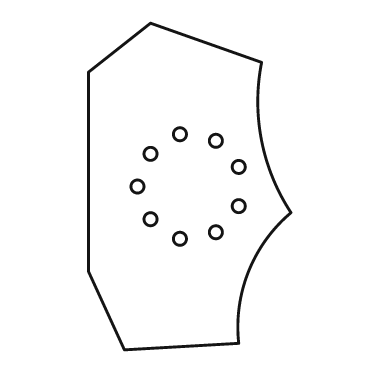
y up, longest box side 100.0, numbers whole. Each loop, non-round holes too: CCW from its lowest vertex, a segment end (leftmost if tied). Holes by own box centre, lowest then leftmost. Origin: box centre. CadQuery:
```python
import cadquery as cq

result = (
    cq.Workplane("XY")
    .moveTo(-20.0, -50.0)
    .lineTo(15.0, -48.0)
    .threePointArc((18.0, -26.0), (31.0, -8.0))
    .threePointArc((22.0, 14.0), (22.0, 38.0))
    .lineTo(-12.0, 50.0)
    .lineTo(-31.0, 35.0)
    .lineTo(-31.0, -26.0)
    .close()
    .moveTo(-3.0, -16.0)
    .circle(2.0)
    .moveTo(8.0, -14.0)
    .circle(2.0)
    .moveTo(-12.0, -10.0)
    .circle(2.0)
    .moveTo(15.0, -6.0)
    .circle(2.0)
    .moveTo(-16.0, 0.0)
    .circle(2.0)
    .moveTo(15.0, 6.0)
    .circle(2.0)
    .moveTo(-12.0, 10.0)
    .circle(2.0)
    .moveTo(8.0, 14.0)
    .circle(2.0)
    .moveTo(-3.0, 16.0)
    .circle(2.0)
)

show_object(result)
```